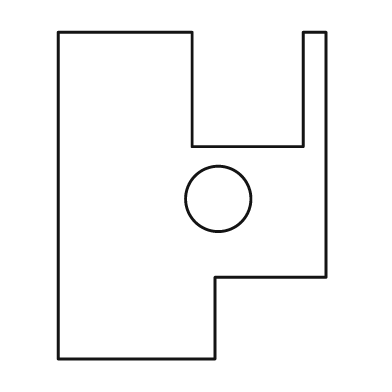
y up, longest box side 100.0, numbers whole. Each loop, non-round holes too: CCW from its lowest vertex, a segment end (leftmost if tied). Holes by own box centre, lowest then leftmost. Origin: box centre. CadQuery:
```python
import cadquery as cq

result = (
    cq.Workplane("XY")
    .moveTo(-41.0, -50.0)
    .lineTo(7.0, -50.0)
    .lineTo(7.0, -25.0)
    .lineTo(41.0, -25.0)
    .lineTo(41.0, 50.0)
    .lineTo(34.0, 50.0)
    .lineTo(34.0, 15.0)
    .lineTo(0.0, 15.0)
    .lineTo(0.0, 50.0)
    .lineTo(-41.0, 50.0)
    .close()
    .moveTo(8.0, -1.0)
    .circle(10.0)
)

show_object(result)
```